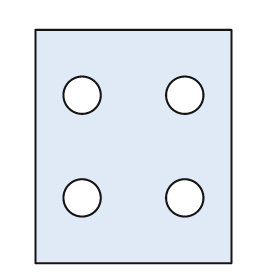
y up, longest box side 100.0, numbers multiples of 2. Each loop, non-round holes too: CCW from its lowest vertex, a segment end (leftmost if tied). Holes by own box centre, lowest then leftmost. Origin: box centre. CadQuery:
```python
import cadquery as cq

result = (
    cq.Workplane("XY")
    .moveTo(-42.0, -50.0)
    .lineTo(42.0, -50.0)
    .lineTo(42.0, 50.0)
    .lineTo(-42.0, 50.0)
    .close()
    .moveTo(-22.0, -22.0)
    .circle(8.0)
    .moveTo(22.0, -22.0)
    .circle(8.0)
    .moveTo(-22.0, 22.0)
    .circle(8.0)
    .moveTo(22.0, 22.0)
    .circle(8.0)
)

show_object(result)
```